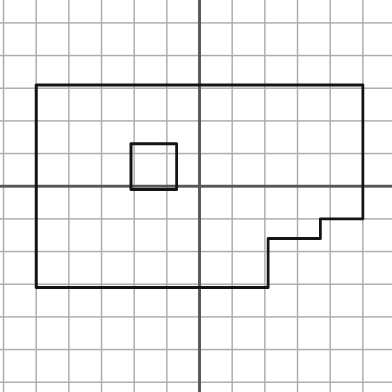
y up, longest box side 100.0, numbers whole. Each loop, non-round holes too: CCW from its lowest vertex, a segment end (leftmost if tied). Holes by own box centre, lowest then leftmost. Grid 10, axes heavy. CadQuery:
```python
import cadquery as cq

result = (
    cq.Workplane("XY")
    .moveTo(-50.0, -31.0)
    .lineTo(21.0, -31.0)
    .lineTo(21.0, -16.0)
    .lineTo(37.0, -16.0)
    .lineTo(37.0, -10.0)
    .lineTo(50.0, -10.0)
    .lineTo(50.0, 31.0)
    .lineTo(-50.0, 31.0)
    .close()
    .moveTo(-21.0, -1.0)
    .lineTo(-7.0, -1.0)
    .lineTo(-7.0, 13.0)
    .lineTo(-21.0, 13.0)
    .close()
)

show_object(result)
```